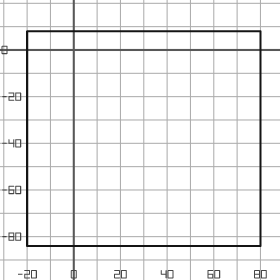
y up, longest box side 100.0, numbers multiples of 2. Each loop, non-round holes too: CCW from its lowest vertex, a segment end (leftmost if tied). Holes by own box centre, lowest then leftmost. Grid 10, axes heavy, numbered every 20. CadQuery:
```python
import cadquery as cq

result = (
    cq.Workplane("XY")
    .moveTo(-20.0, -84.0)
    .lineTo(80.0, -84.0)
    .lineTo(80.0, 8.0)
    .lineTo(-20.0, 8.0)
    .close()
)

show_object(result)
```